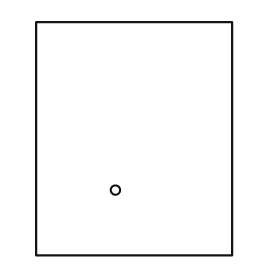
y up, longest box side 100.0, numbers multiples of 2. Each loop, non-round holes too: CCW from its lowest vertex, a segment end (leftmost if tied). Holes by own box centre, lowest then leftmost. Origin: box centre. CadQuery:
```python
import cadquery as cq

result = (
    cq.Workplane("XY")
    .moveTo(-42.0, -50.0)
    .lineTo(42.0, -50.0)
    .lineTo(42.0, 50.0)
    .lineTo(-42.0, 50.0)
    .close()
    .moveTo(-8.0, -22.0)
    .circle(2.0)
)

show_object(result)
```